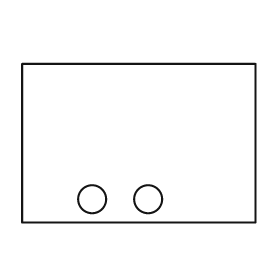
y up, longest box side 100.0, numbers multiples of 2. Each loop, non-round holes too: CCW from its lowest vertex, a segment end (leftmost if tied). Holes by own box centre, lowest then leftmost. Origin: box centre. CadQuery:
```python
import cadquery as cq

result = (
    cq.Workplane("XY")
    .moveTo(-50.0, -34.0)
    .lineTo(50.0, -34.0)
    .lineTo(50.0, 34.0)
    .lineTo(-50.0, 34.0)
    .close()
    .moveTo(-20.0, -24.0)
    .circle(6.0)
    .moveTo(4.0, -24.0)
    .circle(6.0)
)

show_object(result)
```